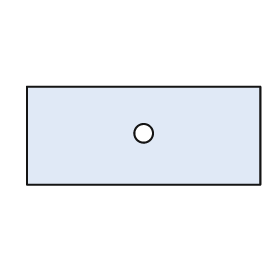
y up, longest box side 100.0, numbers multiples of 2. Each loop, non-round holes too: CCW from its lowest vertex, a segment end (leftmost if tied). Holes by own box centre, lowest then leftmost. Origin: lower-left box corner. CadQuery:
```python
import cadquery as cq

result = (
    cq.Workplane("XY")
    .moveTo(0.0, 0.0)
    .lineTo(100.0, 0.0)
    .lineTo(100.0, 42.0)
    .lineTo(0.0, 42.0)
    .close()
    .moveTo(50.0, 22.0)
    .circle(4.0)
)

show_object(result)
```